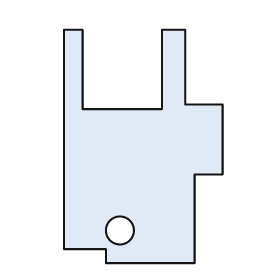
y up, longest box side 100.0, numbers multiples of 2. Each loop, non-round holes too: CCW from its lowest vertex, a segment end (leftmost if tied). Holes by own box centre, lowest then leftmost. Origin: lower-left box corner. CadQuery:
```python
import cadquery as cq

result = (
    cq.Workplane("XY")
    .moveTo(18.0, 0.0)
    .lineTo(56.0, 0.0)
    .lineTo(56.0, 38.0)
    .lineTo(68.0, 38.0)
    .lineTo(68.0, 68.0)
    .lineTo(52.0, 68.0)
    .lineTo(52.0, 100.0)
    .lineTo(42.0, 100.0)
    .lineTo(42.0, 66.0)
    .lineTo(8.0, 66.0)
    .lineTo(8.0, 100.0)
    .lineTo(0.0, 100.0)
    .lineTo(0.0, 6.0)
    .lineTo(18.0, 6.0)
    .close()
    .moveTo(24.0, 14.0)
    .circle(6.0)
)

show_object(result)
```